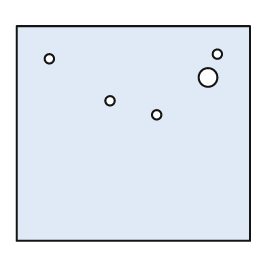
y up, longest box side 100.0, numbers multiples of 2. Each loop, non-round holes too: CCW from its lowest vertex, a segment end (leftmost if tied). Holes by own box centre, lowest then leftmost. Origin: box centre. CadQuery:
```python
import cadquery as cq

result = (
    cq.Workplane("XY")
    .moveTo(-50.0, -46.0)
    .lineTo(50.0, -46.0)
    .lineTo(50.0, 46.0)
    .lineTo(-50.0, 46.0)
    .close()
    .moveTo(10.0, 8.0)
    .circle(2.0)
    .moveTo(-10.0, 14.0)
    .circle(2.0)
    .moveTo(32.0, 24.0)
    .circle(4.0)
    .moveTo(-36.0, 32.0)
    .circle(2.0)
    .moveTo(36.0, 34.0)
    .circle(2.0)
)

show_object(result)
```